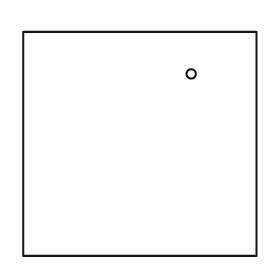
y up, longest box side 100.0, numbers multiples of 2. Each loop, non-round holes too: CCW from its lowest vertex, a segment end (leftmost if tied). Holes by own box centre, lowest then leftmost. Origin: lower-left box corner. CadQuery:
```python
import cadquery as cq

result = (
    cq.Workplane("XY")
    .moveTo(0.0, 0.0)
    .lineTo(100.0, 0.0)
    .lineTo(100.0, 96.0)
    .lineTo(0.0, 96.0)
    .close()
    .moveTo(72.0, 78.0)
    .circle(2.0)
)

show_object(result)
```